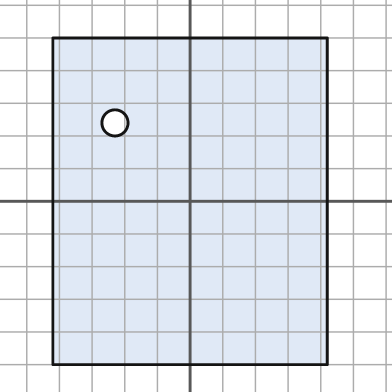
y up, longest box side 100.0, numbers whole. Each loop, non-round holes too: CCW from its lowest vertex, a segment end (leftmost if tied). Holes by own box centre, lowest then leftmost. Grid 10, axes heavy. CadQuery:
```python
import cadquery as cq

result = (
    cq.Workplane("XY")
    .moveTo(-42.0, -50.0)
    .lineTo(42.0, -50.0)
    .lineTo(42.0, 50.0)
    .lineTo(-42.0, 50.0)
    .close()
    .moveTo(-23.0, 24.0)
    .circle(4.0)
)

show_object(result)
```